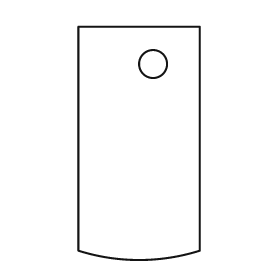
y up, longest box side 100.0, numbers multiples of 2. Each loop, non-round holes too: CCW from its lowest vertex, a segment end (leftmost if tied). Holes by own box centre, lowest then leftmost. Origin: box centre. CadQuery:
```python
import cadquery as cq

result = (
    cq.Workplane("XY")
    .moveTo(-26.0, -46.0)
    .threePointArc((0.0, -50.0), (26.0, -46.0))
    .lineTo(26.0, 50.0)
    .lineTo(-26.0, 50.0)
    .close()
    .moveTo(6.0, 34.0)
    .circle(6.0)
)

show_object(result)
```